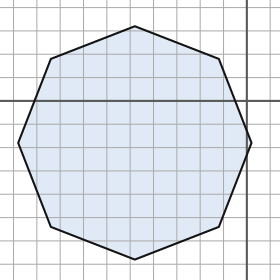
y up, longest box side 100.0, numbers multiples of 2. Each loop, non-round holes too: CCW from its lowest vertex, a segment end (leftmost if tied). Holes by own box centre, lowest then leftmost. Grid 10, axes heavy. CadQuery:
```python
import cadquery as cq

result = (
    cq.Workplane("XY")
    .moveTo(-48.0, -68.0)
    .lineTo(-12.0, -54.0)
    .lineTo(2.0, -18.0)
    .lineTo(-12.0, 18.0)
    .lineTo(-48.0, 32.0)
    .lineTo(-84.0, 18.0)
    .lineTo(-98.0, -18.0)
    .lineTo(-84.0, -54.0)
    .close()
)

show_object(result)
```